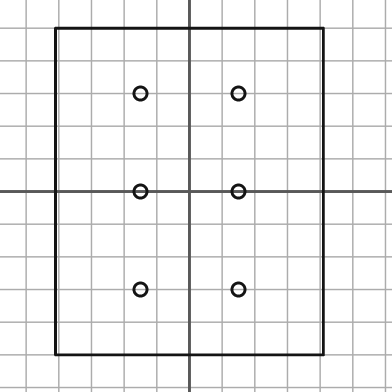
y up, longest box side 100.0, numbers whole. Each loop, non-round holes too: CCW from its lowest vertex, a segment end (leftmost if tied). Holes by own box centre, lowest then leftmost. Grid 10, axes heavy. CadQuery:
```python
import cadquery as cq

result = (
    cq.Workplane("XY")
    .moveTo(-41.0, -50.0)
    .lineTo(41.0, -50.0)
    .lineTo(41.0, 50.0)
    .lineTo(-41.0, 50.0)
    .close()
    .moveTo(-15.0, -30.0)
    .circle(2.0)
    .moveTo(15.0, -30.0)
    .circle(2.0)
    .moveTo(-15.0, 0.0)
    .circle(2.0)
    .moveTo(15.0, 0.0)
    .circle(2.0)
    .moveTo(-15.0, 30.0)
    .circle(2.0)
    .moveTo(15.0, 30.0)
    .circle(2.0)
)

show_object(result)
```